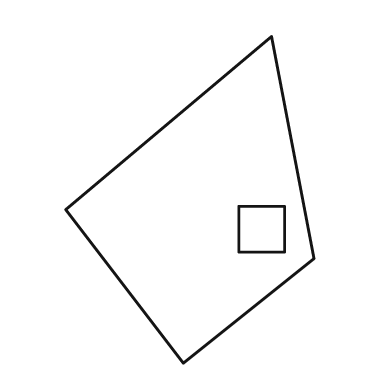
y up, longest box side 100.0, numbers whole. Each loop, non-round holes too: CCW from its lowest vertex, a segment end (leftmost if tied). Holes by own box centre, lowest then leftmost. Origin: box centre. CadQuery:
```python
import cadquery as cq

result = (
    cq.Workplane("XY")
    .moveTo(-2.0, -50.0)
    .lineTo(38.0, -18.0)
    .lineTo(25.0, 50.0)
    .lineTo(-38.0, -3.0)
    .close()
    .moveTo(15.0, -16.0)
    .lineTo(29.0, -16.0)
    .lineTo(29.0, -2.0)
    .lineTo(15.0, -2.0)
    .close()
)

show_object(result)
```